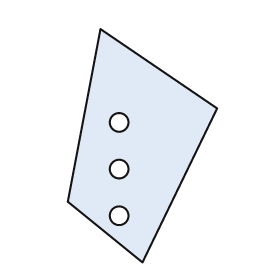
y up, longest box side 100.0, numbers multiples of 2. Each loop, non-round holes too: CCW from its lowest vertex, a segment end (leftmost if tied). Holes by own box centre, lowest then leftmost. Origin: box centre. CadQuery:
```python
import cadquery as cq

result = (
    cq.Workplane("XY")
    .moveTo(0.0, -50.0)
    .lineTo(32.0, 16.0)
    .lineTo(-18.0, 50.0)
    .lineTo(-32.0, -24.0)
    .close()
    .moveTo(-10.0, -30.0)
    .circle(4.0)
    .moveTo(-10.0, -10.0)
    .circle(4.0)
    .moveTo(-10.0, 10.0)
    .circle(4.0)
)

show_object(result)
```